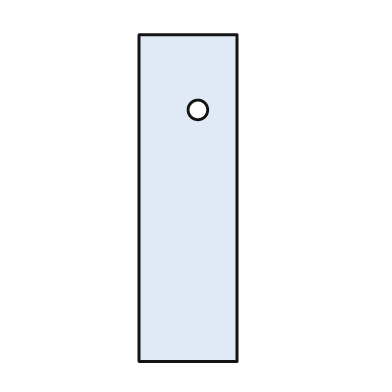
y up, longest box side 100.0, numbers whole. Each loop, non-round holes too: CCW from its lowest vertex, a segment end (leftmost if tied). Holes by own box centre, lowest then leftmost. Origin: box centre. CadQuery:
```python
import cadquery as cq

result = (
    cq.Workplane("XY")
    .moveTo(-15.0, -50.0)
    .lineTo(15.0, -50.0)
    .lineTo(15.0, 50.0)
    .lineTo(-15.0, 50.0)
    .close()
    .moveTo(3.0, 27.0)
    .circle(3.0)
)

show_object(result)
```